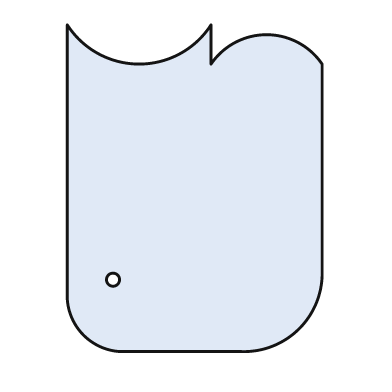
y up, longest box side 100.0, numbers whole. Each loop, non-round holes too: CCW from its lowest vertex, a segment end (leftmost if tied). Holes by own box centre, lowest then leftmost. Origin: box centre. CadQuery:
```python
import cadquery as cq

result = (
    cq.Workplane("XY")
    .moveTo(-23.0, -50.0)
    .lineTo(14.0, -50.0)
    .threePointArc((32.0, -43.0), (39.0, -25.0))
    .lineTo(39.0, 38.0)
    .threePointArc((22.0, 47.0), (5.0, 38.0))
    .lineTo(5.0, 50.0)
    .threePointArc((-17.0, 38.0), (-39.0, 50.0))
    .lineTo(-39.0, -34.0)
    .threePointArc((-34.0, -45.0), (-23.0, -50.0))
    .close()
    .moveTo(-25.0, -28.0)
    .circle(2.0)
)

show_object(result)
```